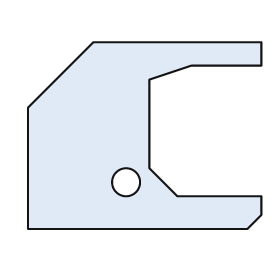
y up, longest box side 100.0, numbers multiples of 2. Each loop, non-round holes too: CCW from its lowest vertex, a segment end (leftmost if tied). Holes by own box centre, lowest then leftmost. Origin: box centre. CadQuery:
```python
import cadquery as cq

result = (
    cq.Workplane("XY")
    .moveTo(-50.0, -40.0)
    .lineTo(44.0, -40.0)
    .lineTo(50.0, -34.0)
    .lineTo(50.0, -26.0)
    .lineTo(14.0, -26.0)
    .lineTo(2.0, -14.0)
    .lineTo(2.0, 24.0)
    .lineTo(20.0, 30.0)
    .lineTo(50.0, 30.0)
    .lineTo(50.0, 40.0)
    .lineTo(-22.0, 40.0)
    .lineTo(-50.0, 12.0)
    .close()
    .moveTo(-8.0, -20.0)
    .circle(6.0)
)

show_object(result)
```